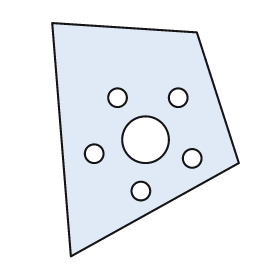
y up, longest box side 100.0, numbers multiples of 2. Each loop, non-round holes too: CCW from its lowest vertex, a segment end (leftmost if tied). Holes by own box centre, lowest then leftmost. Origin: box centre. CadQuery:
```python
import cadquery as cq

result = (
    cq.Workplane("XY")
    .moveTo(-32.0, -50.0)
    .lineTo(40.0, -10.0)
    .lineTo(22.0, 46.0)
    .lineTo(-40.0, 50.0)
    .close()
    .moveTo(-2.0, -22.0)
    .circle(4.0)
    .moveTo(20.0, -8.0)
    .circle(4.0)
    .moveTo(-22.0, -6.0)
    .circle(4.0)
    .moveTo(0.0, 0.0)
    .circle(10.0)
    .moveTo(-12.0, 18.0)
    .circle(4.0)
    .moveTo(14.0, 18.0)
    .circle(4.0)
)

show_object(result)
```